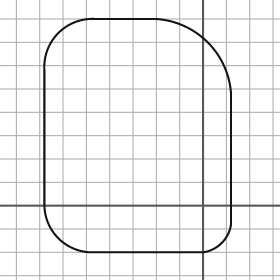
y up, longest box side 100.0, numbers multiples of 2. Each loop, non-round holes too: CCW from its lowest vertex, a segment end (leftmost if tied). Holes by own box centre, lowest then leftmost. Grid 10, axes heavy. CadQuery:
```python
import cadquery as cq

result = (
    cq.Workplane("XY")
    .moveTo(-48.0, -20.0)
    .lineTo(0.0, -20.0)
    .threePointArc((8.0, -16.0), (12.0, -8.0))
    .lineTo(12.0, 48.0)
    .threePointArc((2.0, 70.0), (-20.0, 80.0))
    .lineTo(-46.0, 80.0)
    .threePointArc((-62.0, 74.0), (-68.0, 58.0))
    .lineTo(-68.0, 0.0)
    .threePointArc((-62.0, -14.0), (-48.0, -20.0))
    .close()
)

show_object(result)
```